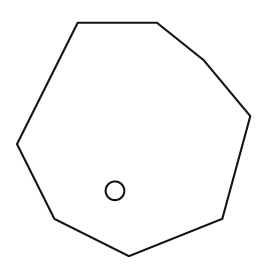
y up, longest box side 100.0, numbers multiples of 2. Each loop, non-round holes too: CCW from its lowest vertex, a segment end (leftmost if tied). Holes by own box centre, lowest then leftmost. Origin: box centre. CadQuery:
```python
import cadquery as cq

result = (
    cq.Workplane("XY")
    .moveTo(-2.0, -50.0)
    .lineTo(38.0, -34.0)
    .lineTo(50.0, 10.0)
    .lineTo(30.0, 34.0)
    .lineTo(10.0, 50.0)
    .lineTo(-24.0, 50.0)
    .lineTo(-50.0, -2.0)
    .lineTo(-34.0, -34.0)
    .close()
    .moveTo(-8.0, -22.0)
    .circle(4.0)
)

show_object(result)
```